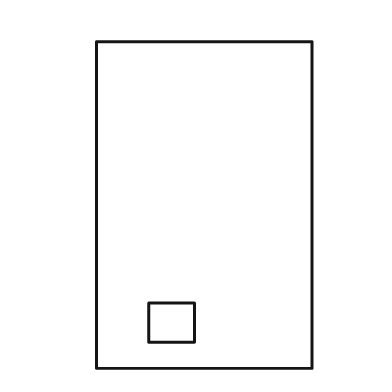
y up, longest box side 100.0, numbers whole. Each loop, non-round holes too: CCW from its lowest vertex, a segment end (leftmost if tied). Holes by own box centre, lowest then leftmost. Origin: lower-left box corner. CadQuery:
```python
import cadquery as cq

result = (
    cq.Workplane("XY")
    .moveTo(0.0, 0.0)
    .lineTo(66.0, 0.0)
    .lineTo(66.0, 100.0)
    .lineTo(0.0, 100.0)
    .close()
    .moveTo(16.0, 8.0)
    .lineTo(30.0, 8.0)
    .lineTo(30.0, 20.0)
    .lineTo(16.0, 20.0)
    .close()
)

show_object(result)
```